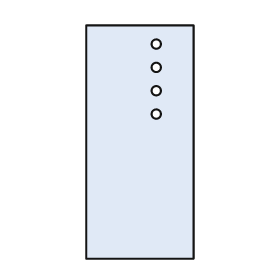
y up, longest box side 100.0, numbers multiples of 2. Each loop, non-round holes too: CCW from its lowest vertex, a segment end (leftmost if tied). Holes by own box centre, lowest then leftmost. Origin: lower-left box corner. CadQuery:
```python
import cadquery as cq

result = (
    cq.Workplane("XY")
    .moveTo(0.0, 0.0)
    .lineTo(46.0, 0.0)
    .lineTo(46.0, 100.0)
    .lineTo(0.0, 100.0)
    .close()
    .moveTo(30.0, 62.0)
    .circle(2.0)
    .moveTo(30.0, 72.0)
    .circle(2.0)
    .moveTo(30.0, 82.0)
    .circle(2.0)
    .moveTo(30.0, 92.0)
    .circle(2.0)
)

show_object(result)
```